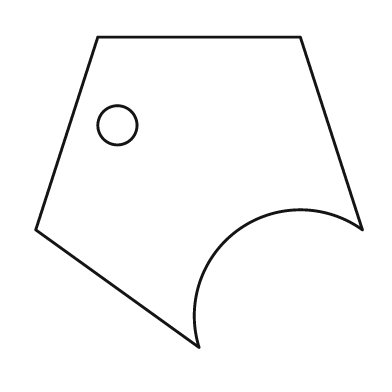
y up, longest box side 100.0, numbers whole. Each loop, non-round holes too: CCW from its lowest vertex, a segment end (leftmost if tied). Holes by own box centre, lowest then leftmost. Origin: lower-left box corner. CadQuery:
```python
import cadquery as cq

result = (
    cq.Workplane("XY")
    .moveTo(50.0, 0.0)
    .threePointArc((62.0, 36.0), (100.0, 36.0))
    .lineTo(81.0, 95.0)
    .lineTo(19.0, 95.0)
    .lineTo(0.0, 36.0)
    .close()
    .moveTo(25.0, 68.0)
    .circle(6.0)
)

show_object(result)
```